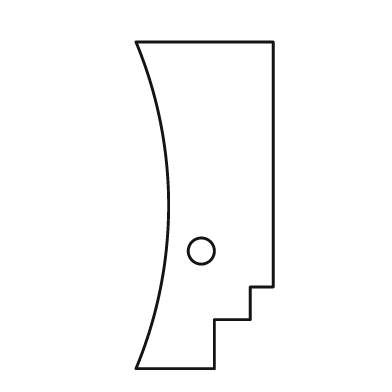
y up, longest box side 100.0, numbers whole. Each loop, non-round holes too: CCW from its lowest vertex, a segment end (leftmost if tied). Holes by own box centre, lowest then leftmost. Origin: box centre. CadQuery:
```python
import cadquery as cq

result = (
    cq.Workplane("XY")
    .moveTo(-21.0, -50.0)
    .lineTo(3.0, -50.0)
    .lineTo(3.0, -35.0)
    .lineTo(14.0, -35.0)
    .lineTo(14.0, -25.0)
    .lineTo(21.0, -25.0)
    .lineTo(21.0, 50.0)
    .lineTo(-21.0, 50.0)
    .threePointArc((-11.0, 0.0), (-21.0, -50.0))
    .close()
    .moveTo(-1.0, -14.0)
    .circle(4.0)
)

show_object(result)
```